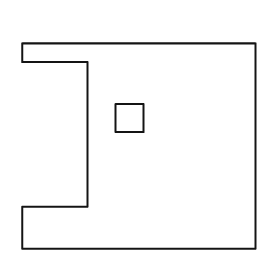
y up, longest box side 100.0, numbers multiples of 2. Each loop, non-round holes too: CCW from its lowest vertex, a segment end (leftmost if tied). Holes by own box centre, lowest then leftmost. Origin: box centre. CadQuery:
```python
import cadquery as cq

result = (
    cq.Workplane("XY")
    .moveTo(-50.0, -44.0)
    .lineTo(50.0, -44.0)
    .lineTo(50.0, 44.0)
    .lineTo(-50.0, 44.0)
    .lineTo(-50.0, 36.0)
    .lineTo(-22.0, 36.0)
    .lineTo(-22.0, -26.0)
    .lineTo(-50.0, -26.0)
    .close()
    .moveTo(-10.0, 6.0)
    .lineTo(2.0, 6.0)
    .lineTo(2.0, 18.0)
    .lineTo(-10.0, 18.0)
    .close()
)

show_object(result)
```